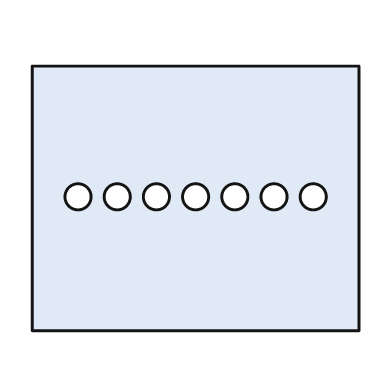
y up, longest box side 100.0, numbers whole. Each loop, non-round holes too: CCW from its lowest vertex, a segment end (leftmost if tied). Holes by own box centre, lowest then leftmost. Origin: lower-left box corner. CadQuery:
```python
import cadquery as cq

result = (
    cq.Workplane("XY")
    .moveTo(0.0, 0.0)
    .lineTo(100.0, 0.0)
    .lineTo(100.0, 81.0)
    .lineTo(0.0, 81.0)
    .close()
    .moveTo(14.0, 41.0)
    .circle(4.0)
    .moveTo(26.0, 41.0)
    .circle(4.0)
    .moveTo(38.0, 41.0)
    .circle(4.0)
    .moveTo(50.0, 41.0)
    .circle(4.0)
    .moveTo(62.0, 41.0)
    .circle(4.0)
    .moveTo(74.0, 41.0)
    .circle(4.0)
    .moveTo(86.0, 41.0)
    .circle(4.0)
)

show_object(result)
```